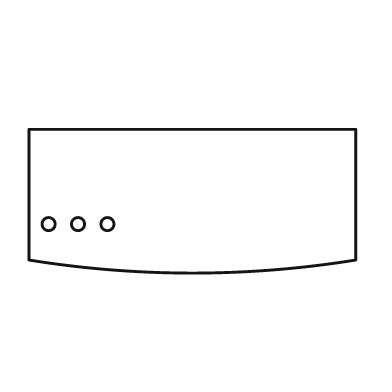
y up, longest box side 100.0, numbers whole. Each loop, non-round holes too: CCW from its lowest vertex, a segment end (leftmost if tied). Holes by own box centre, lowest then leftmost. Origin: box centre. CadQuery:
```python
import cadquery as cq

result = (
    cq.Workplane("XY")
    .moveTo(-50.0, -18.0)
    .threePointArc((0.0, -22.0), (50.0, -18.0))
    .lineTo(50.0, 22.0)
    .lineTo(-50.0, 22.0)
    .close()
    .moveTo(-44.0, -7.0)
    .circle(2.0)
    .moveTo(-35.0, -7.0)
    .circle(2.0)
    .moveTo(-26.0, -7.0)
    .circle(2.0)
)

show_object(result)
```